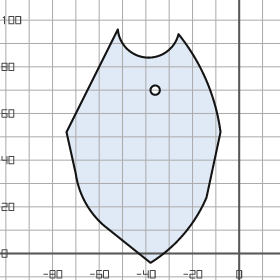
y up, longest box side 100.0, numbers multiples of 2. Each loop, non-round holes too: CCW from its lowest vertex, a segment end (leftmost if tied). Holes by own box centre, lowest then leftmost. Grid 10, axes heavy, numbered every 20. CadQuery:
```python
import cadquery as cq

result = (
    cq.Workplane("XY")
    .moveTo(-38.0, -4.0)
    .threePointArc((-24.0, 8.0), (-14.0, 24.0))
    .lineTo(-8.0, 52.0)
    .threePointArc((-14.0, 74.0), (-26.0, 94.0))
    .threePointArc((-40.0, 84.0), (-52.0, 96.0))
    .lineTo(-74.0, 52.0)
    .lineTo(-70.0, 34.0)
    .threePointArc((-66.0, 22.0), (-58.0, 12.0))
    .close()
    .moveTo(-36.0, 70.0)
    .circle(2.0)
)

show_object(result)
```